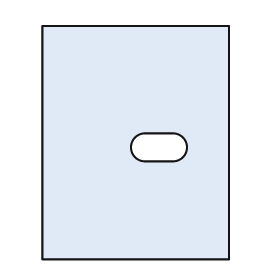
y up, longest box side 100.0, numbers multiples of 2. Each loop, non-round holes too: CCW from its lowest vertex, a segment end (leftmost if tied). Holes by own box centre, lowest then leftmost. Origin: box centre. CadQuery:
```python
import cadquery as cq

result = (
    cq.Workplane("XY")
    .moveTo(-40.0, -50.0)
    .lineTo(40.0, -50.0)
    .lineTo(40.0, 50.0)
    .lineTo(-40.0, 50.0)
    .close()
    .moveTo(4.0, -8.0)
    .lineTo(16.0, -8.0)
    .threePointArc((22.0, -2.0), (16.0, 4.0))
    .lineTo(4.0, 4.0)
    .threePointArc((-2.0, -2.0), (4.0, -8.0))
    .close()
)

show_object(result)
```